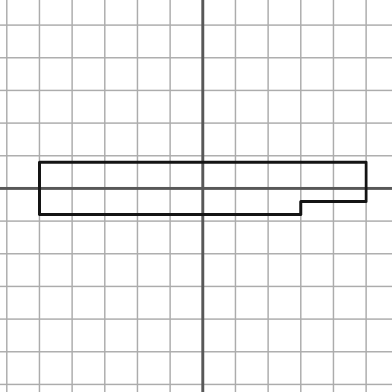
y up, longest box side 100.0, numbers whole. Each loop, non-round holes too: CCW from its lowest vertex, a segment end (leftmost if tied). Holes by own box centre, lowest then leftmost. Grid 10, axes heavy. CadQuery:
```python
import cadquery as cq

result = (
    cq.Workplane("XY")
    .moveTo(-50.0, -8.0)
    .lineTo(30.0, -8.0)
    .lineTo(30.0, -4.0)
    .lineTo(50.0, -4.0)
    .lineTo(50.0, 8.0)
    .lineTo(-50.0, 8.0)
    .close()
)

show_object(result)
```